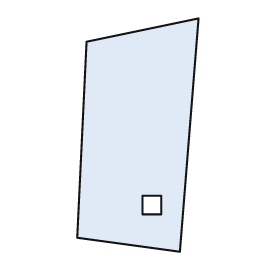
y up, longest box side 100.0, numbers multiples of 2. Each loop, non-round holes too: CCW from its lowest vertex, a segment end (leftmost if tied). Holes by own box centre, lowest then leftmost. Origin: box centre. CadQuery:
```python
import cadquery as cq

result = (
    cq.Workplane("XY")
    .moveTo(18.0, -50.0)
    .lineTo(26.0, 50.0)
    .lineTo(-22.0, 40.0)
    .lineTo(-26.0, -44.0)
    .close()
    .moveTo(2.0, -34.0)
    .lineTo(10.0, -34.0)
    .lineTo(10.0, -26.0)
    .lineTo(2.0, -26.0)
    .close()
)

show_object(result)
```